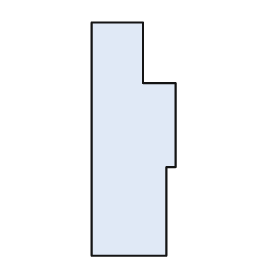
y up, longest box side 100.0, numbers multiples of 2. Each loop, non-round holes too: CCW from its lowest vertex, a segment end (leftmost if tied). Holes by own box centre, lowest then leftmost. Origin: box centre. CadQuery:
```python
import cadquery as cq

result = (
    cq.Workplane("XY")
    .moveTo(-18.0, -50.0)
    .lineTo(14.0, -50.0)
    .lineTo(14.0, -12.0)
    .lineTo(18.0, -12.0)
    .lineTo(18.0, 24.0)
    .lineTo(4.0, 24.0)
    .lineTo(4.0, 50.0)
    .lineTo(-18.0, 50.0)
    .close()
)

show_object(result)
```